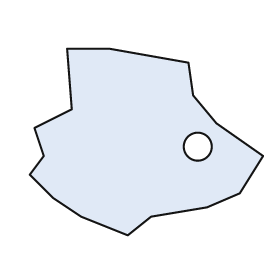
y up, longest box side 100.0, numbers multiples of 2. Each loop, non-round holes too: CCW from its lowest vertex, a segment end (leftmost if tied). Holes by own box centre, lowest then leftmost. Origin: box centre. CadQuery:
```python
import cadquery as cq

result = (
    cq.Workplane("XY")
    .moveTo(-8.0, -40.0)
    .lineTo(2.0, -32.0)
    .lineTo(26.0, -28.0)
    .lineTo(40.0, -22.0)
    .lineTo(50.0, -6.0)
    .lineTo(30.0, 8.0)
    .lineTo(20.0, 20.0)
    .lineTo(18.0, 34.0)
    .lineTo(-16.0, 40.0)
    .lineTo(-34.0, 40.0)
    .lineTo(-32.0, 14.0)
    .lineTo(-48.0, 6.0)
    .lineTo(-44.0, -6.0)
    .lineTo(-50.0, -14.0)
    .lineTo(-40.0, -24.0)
    .lineTo(-28.0, -32.0)
    .close()
    .moveTo(22.0, -2.0)
    .circle(6.0)
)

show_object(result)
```